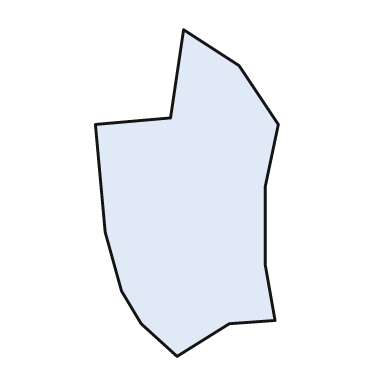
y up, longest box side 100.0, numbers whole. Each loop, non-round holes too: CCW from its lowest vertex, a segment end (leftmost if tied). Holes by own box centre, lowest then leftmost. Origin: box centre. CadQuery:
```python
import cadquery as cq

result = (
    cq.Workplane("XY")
    .moveTo(-3.0, -50.0)
    .lineTo(13.0, -40.0)
    .lineTo(27.0, -39.0)
    .lineTo(24.0, -22.0)
    .lineTo(24.0, 2.0)
    .lineTo(28.0, 21.0)
    .lineTo(16.0, 39.0)
    .lineTo(-1.0, 50.0)
    .lineTo(-5.0, 23.0)
    .lineTo(-28.0, 21.0)
    .lineTo(-25.0, -12.0)
    .lineTo(-20.0, -30.0)
    .lineTo(-14.0, -40.0)
    .close()
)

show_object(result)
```